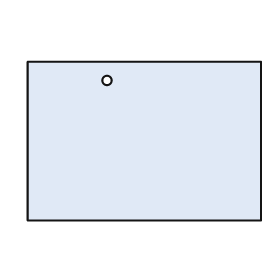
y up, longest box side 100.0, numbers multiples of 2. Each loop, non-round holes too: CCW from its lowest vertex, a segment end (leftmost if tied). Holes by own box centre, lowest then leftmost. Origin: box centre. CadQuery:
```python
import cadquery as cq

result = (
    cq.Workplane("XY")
    .moveTo(-50.0, -34.0)
    .lineTo(50.0, -34.0)
    .lineTo(50.0, 34.0)
    .lineTo(-50.0, 34.0)
    .close()
    .moveTo(-16.0, 26.0)
    .circle(2.0)
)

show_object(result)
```